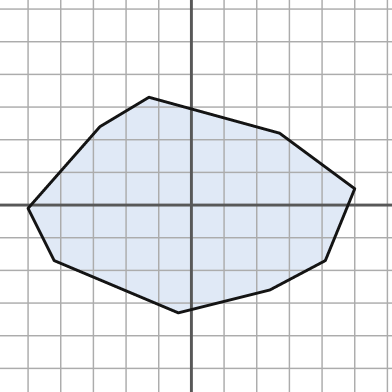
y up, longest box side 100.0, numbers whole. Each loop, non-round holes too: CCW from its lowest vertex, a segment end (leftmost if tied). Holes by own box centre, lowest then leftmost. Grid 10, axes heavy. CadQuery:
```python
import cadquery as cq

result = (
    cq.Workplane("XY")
    .moveTo(-4.0, -33.0)
    .lineTo(24.0, -26.0)
    .lineTo(41.0, -17.0)
    .lineTo(50.0, 5.0)
    .lineTo(27.0, 22.0)
    .lineTo(-13.0, 33.0)
    .lineTo(-28.0, 24.0)
    .lineTo(-50.0, -1.0)
    .lineTo(-42.0, -17.0)
    .close()
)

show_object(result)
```